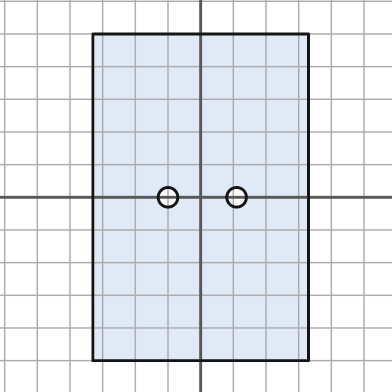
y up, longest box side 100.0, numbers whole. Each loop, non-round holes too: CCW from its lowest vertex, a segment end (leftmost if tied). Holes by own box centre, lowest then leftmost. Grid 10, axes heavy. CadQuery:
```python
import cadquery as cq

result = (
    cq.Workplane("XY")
    .moveTo(-33.0, -50.0)
    .lineTo(33.0, -50.0)
    .lineTo(33.0, 50.0)
    .lineTo(-33.0, 50.0)
    .close()
    .moveTo(-10.0, 0.0)
    .circle(3.0)
    .moveTo(11.0, 0.0)
    .circle(3.0)
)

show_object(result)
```